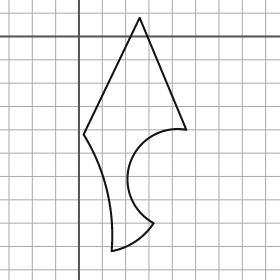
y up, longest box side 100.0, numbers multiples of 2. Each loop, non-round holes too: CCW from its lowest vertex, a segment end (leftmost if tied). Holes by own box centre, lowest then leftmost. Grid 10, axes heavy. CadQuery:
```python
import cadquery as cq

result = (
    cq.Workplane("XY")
    .moveTo(14.0, -92.0)
    .threePointArc((24.0, -88.0), (32.0, -80.0))
    .threePointArc((22.0, -54.0), (46.0, -40.0))
    .lineTo(26.0, 8.0)
    .lineTo(2.0, -42.0)
    .threePointArc((12.0, -66.0), (14.0, -92.0))
    .close()
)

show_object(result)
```